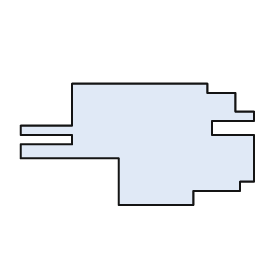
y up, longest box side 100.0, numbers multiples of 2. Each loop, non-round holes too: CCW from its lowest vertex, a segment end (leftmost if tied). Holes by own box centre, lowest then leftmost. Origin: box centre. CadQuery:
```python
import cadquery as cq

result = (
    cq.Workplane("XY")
    .moveTo(-8.0, -26.0)
    .lineTo(24.0, -26.0)
    .lineTo(24.0, -20.0)
    .lineTo(44.0, -20.0)
    .lineTo(44.0, -16.0)
    .lineTo(50.0, -16.0)
    .lineTo(50.0, 4.0)
    .lineTo(32.0, 4.0)
    .lineTo(32.0, 10.0)
    .lineTo(50.0, 10.0)
    .lineTo(50.0, 14.0)
    .lineTo(42.0, 14.0)
    .lineTo(42.0, 22.0)
    .lineTo(30.0, 22.0)
    .lineTo(30.0, 26.0)
    .lineTo(-28.0, 26.0)
    .lineTo(-28.0, 8.0)
    .lineTo(-50.0, 8.0)
    .lineTo(-50.0, 4.0)
    .lineTo(-28.0, 4.0)
    .lineTo(-28.0, 0.0)
    .lineTo(-50.0, 0.0)
    .lineTo(-50.0, -6.0)
    .lineTo(-8.0, -6.0)
    .close()
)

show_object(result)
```